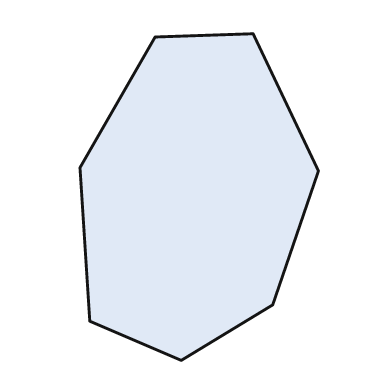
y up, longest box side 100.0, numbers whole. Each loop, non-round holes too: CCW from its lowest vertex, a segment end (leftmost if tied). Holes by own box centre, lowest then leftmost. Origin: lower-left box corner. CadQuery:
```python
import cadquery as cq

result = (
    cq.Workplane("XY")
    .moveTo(31.0, 0.0)
    .lineTo(59.0, 17.0)
    .lineTo(73.0, 58.0)
    .lineTo(53.0, 100.0)
    .lineTo(23.0, 99.0)
    .lineTo(0.0, 59.0)
    .lineTo(3.0, 12.0)
    .close()
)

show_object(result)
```